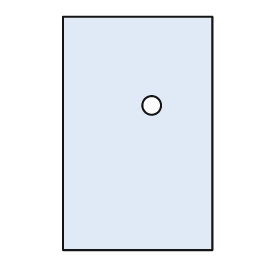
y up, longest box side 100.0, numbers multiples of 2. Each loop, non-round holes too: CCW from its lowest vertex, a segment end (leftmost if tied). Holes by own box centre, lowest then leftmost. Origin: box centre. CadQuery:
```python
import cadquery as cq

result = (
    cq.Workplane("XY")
    .moveTo(-32.0, -50.0)
    .lineTo(32.0, -50.0)
    .lineTo(32.0, 50.0)
    .lineTo(-32.0, 50.0)
    .close()
    .moveTo(6.0, 12.0)
    .circle(4.0)
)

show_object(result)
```